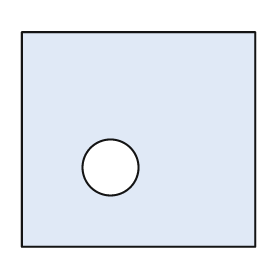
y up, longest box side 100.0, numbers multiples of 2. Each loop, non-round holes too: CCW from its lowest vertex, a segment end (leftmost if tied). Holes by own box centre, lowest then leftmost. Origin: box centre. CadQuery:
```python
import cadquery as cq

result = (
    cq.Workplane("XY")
    .moveTo(-50.0, -46.0)
    .lineTo(50.0, -46.0)
    .lineTo(50.0, 46.0)
    .lineTo(-50.0, 46.0)
    .close()
    .moveTo(-12.0, -12.0)
    .circle(12.0)
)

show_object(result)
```